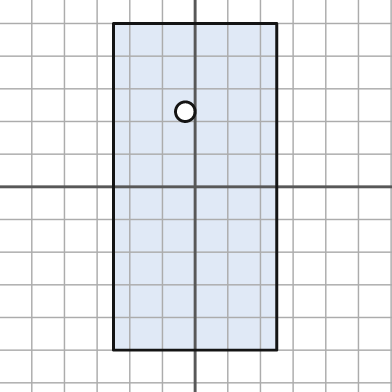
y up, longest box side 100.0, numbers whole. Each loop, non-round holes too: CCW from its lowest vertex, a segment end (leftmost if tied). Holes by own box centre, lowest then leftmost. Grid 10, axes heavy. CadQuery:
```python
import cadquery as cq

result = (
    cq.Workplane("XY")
    .moveTo(-25.0, -50.0)
    .lineTo(25.0, -50.0)
    .lineTo(25.0, 50.0)
    .lineTo(-25.0, 50.0)
    .close()
    .moveTo(-3.0, 23.0)
    .circle(3.0)
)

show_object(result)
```